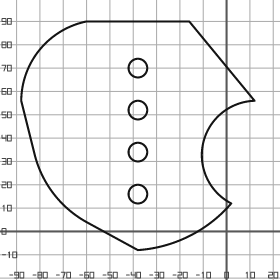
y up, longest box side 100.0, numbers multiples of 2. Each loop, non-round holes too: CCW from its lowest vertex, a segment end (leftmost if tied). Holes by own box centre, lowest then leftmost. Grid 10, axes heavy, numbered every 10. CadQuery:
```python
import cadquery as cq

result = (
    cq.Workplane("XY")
    .moveTo(-38.0, -8.0)
    .threePointArc((-16.0, -2.0), (2.0, 12.0))
    .threePointArc((-10.0, 38.0), (12.0, 56.0))
    .lineTo(-16.0, 90.0)
    .lineTo(-60.0, 90.0)
    .threePointArc((-80.0, 78.0), (-88.0, 56.0))
    .lineTo(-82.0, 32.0)
    .threePointArc((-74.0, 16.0), (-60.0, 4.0))
    .close()
    .moveTo(-38.0, 16.0)
    .circle(4.0)
    .moveTo(-38.0, 34.0)
    .circle(4.0)
    .moveTo(-38.0, 52.0)
    .circle(4.0)
    .moveTo(-38.0, 70.0)
    .circle(4.0)
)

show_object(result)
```